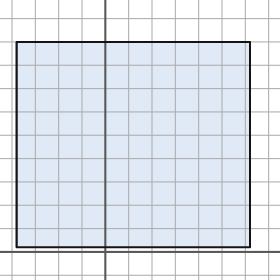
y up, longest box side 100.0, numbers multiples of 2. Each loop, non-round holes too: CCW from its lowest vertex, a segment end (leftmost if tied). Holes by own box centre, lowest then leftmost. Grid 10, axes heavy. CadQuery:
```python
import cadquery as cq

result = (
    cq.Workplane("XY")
    .moveTo(-38.0, 2.0)
    .lineTo(62.0, 2.0)
    .lineTo(62.0, 90.0)
    .lineTo(-38.0, 90.0)
    .close()
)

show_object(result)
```